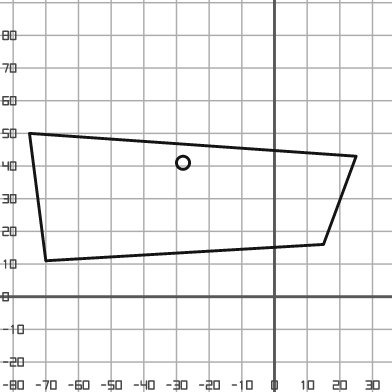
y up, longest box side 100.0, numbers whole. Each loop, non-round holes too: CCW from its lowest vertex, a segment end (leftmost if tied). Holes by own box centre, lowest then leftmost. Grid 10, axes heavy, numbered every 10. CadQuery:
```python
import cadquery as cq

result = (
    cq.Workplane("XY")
    .moveTo(-70.0, 11.0)
    .lineTo(15.0, 16.0)
    .lineTo(25.0, 43.0)
    .lineTo(-75.0, 50.0)
    .close()
    .moveTo(-28.0, 41.0)
    .circle(2.0)
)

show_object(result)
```